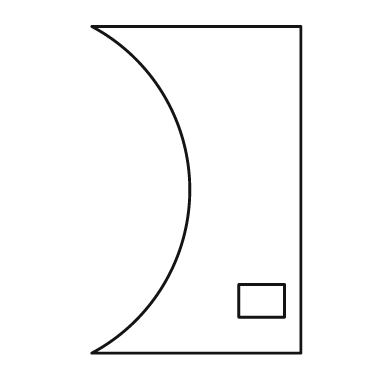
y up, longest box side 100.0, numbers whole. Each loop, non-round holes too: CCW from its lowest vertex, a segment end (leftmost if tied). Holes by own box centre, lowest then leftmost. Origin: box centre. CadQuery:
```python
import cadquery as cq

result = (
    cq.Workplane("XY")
    .moveTo(-32.0, -50.0)
    .lineTo(32.0, -50.0)
    .lineTo(32.0, 50.0)
    .lineTo(-32.0, 50.0)
    .threePointArc((-2.0, 0.0), (-32.0, -50.0))
    .close()
    .moveTo(13.0, -39.0)
    .lineTo(27.0, -39.0)
    .lineTo(27.0, -29.0)
    .lineTo(13.0, -29.0)
    .close()
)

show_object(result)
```